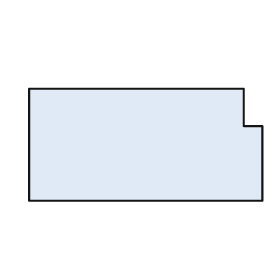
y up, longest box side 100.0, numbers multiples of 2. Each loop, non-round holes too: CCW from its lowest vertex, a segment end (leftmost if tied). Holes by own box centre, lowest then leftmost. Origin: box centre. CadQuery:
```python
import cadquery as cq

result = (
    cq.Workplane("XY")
    .moveTo(-50.0, -24.0)
    .lineTo(50.0, -24.0)
    .lineTo(50.0, 8.0)
    .lineTo(42.0, 8.0)
    .lineTo(42.0, 24.0)
    .lineTo(-50.0, 24.0)
    .close()
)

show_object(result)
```